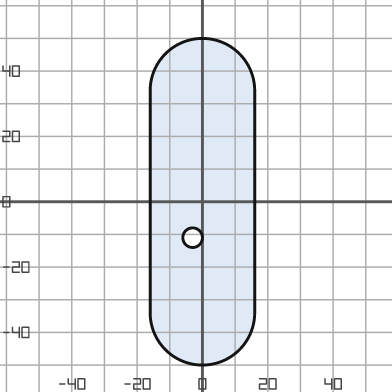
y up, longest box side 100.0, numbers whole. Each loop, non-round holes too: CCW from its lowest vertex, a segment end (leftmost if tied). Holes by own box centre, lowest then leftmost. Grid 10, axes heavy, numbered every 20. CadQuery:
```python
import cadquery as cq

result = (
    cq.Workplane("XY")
    .moveTo(-16.0, -34.0)
    .threePointArc((0.0, -50.0), (16.0, -34.0))
    .lineTo(16.0, 34.0)
    .threePointArc((0.0, 50.0), (-16.0, 34.0))
    .close()
    .moveTo(-3.0, -11.0)
    .circle(3.0)
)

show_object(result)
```